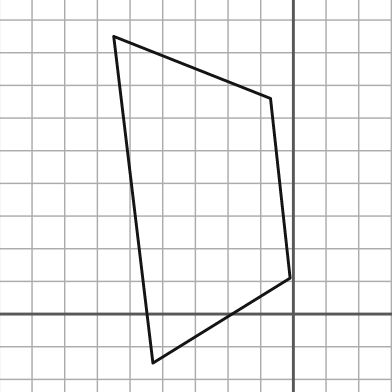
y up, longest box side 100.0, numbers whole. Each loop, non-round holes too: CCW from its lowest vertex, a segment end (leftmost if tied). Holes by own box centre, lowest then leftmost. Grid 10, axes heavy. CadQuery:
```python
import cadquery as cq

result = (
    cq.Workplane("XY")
    .moveTo(-43.0, -15.0)
    .lineTo(-1.0, 11.0)
    .lineTo(-7.0, 66.0)
    .lineTo(-55.0, 85.0)
    .close()
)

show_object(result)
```